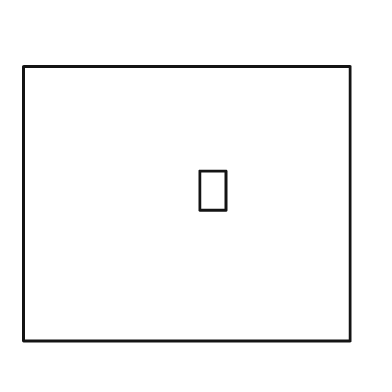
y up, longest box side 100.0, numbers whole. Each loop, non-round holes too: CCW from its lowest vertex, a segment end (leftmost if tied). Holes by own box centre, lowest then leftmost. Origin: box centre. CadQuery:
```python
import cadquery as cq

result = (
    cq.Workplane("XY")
    .moveTo(-50.0, -42.0)
    .lineTo(50.0, -42.0)
    .lineTo(50.0, 42.0)
    .lineTo(-50.0, 42.0)
    .close()
    .moveTo(4.0, -2.0)
    .lineTo(12.0, -2.0)
    .lineTo(12.0, 10.0)
    .lineTo(4.0, 10.0)
    .close()
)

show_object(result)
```